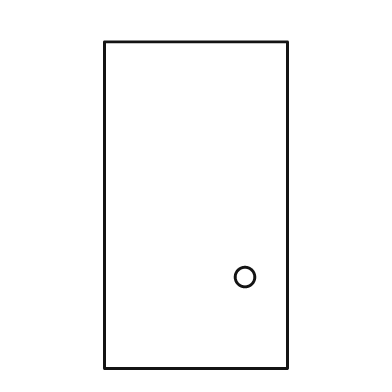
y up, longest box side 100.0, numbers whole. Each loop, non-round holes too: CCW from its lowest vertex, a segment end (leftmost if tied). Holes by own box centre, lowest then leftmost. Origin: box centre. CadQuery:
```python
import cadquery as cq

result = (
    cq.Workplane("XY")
    .moveTo(-28.0, -50.0)
    .lineTo(28.0, -50.0)
    .lineTo(28.0, 50.0)
    .lineTo(-28.0, 50.0)
    .close()
    .moveTo(15.0, -22.0)
    .circle(3.0)
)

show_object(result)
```